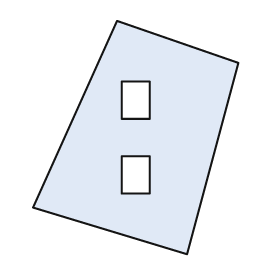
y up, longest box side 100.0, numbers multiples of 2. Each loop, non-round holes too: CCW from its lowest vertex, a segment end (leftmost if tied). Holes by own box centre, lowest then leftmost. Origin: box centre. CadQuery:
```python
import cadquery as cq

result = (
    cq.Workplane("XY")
    .moveTo(22.0, -50.0)
    .lineTo(44.0, 32.0)
    .lineTo(-8.0, 50.0)
    .lineTo(-44.0, -30.0)
    .close()
    .moveTo(-6.0, -24.0)
    .lineTo(6.0, -24.0)
    .lineTo(6.0, -8.0)
    .lineTo(-6.0, -8.0)
    .close()
    .moveTo(-6.0, 8.0)
    .lineTo(6.0, 8.0)
    .lineTo(6.0, 24.0)
    .lineTo(-6.0, 24.0)
    .close()
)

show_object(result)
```